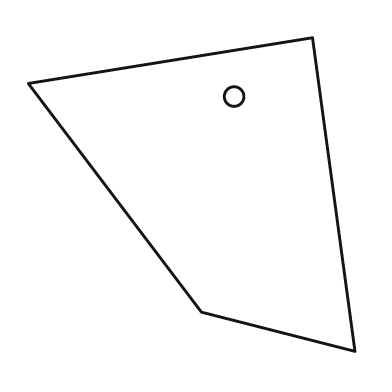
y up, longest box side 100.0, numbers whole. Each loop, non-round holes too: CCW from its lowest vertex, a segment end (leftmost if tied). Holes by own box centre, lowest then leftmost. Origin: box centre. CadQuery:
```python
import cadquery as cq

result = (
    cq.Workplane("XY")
    .moveTo(50.0, -48.0)
    .lineTo(37.0, 48.0)
    .lineTo(-50.0, 34.0)
    .lineTo(3.0, -36.0)
    .close()
    .moveTo(13.0, 30.0)
    .circle(3.0)
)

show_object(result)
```